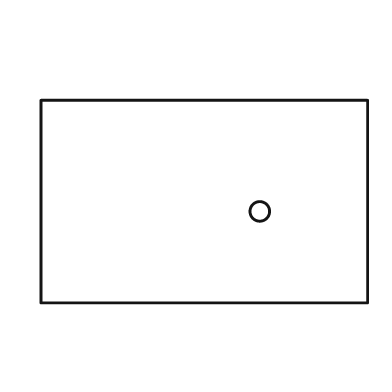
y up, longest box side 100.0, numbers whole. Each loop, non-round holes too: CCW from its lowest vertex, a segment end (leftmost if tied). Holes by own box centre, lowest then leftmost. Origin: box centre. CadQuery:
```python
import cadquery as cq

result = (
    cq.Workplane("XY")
    .moveTo(-50.0, -31.0)
    .lineTo(50.0, -31.0)
    .lineTo(50.0, 31.0)
    .lineTo(-50.0, 31.0)
    .close()
    .moveTo(17.0, -3.0)
    .circle(3.0)
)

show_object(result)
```